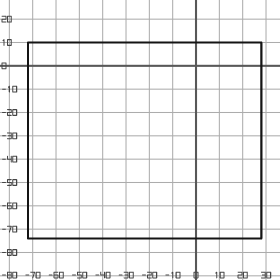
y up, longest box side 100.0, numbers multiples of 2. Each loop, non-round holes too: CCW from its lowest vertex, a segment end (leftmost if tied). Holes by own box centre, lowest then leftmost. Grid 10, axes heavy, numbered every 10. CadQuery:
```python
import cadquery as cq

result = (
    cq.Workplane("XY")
    .moveTo(-72.0, -74.0)
    .lineTo(28.0, -74.0)
    .lineTo(28.0, 10.0)
    .lineTo(-72.0, 10.0)
    .close()
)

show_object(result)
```